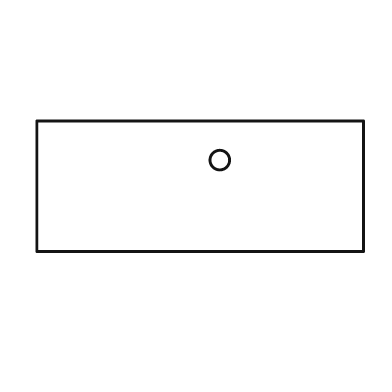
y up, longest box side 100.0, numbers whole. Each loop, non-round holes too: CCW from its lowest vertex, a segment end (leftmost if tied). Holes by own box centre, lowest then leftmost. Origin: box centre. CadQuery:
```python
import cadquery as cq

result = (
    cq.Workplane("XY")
    .moveTo(-50.0, -20.0)
    .lineTo(50.0, -20.0)
    .lineTo(50.0, 20.0)
    .lineTo(-50.0, 20.0)
    .close()
    .moveTo(6.0, 8.0)
    .circle(3.0)
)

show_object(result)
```